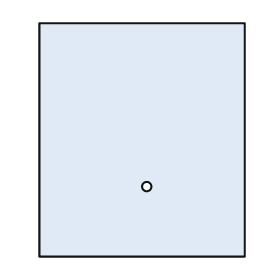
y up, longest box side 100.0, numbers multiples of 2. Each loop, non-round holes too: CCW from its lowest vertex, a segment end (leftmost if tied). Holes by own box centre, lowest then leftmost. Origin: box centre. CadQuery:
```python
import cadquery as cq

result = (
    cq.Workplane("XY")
    .moveTo(-44.0, -50.0)
    .lineTo(44.0, -50.0)
    .lineTo(44.0, 50.0)
    .lineTo(-44.0, 50.0)
    .close()
    .moveTo(2.0, -20.0)
    .circle(2.0)
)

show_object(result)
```